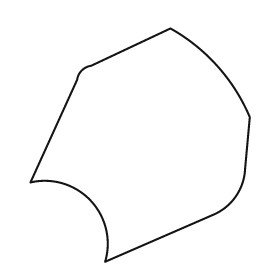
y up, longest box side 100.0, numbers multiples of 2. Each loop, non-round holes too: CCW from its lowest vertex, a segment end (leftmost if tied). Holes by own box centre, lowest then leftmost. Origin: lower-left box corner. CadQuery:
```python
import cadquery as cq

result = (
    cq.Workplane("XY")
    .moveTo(32.0, 0.0)
    .lineTo(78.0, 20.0)
    .threePointArc((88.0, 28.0), (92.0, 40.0))
    .lineTo(94.0, 62.0)
    .threePointArc((80.0, 84.0), (60.0, 100.0))
    .lineTo(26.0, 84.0)
    .threePointArc((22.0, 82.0), (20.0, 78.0))
    .lineTo(0.0, 34.0)
    .threePointArc((26.0, 26.0), (32.0, 0.0))
    .close()
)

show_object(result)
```